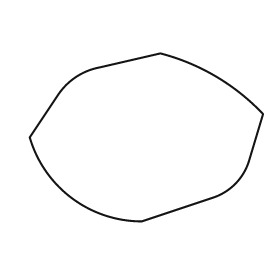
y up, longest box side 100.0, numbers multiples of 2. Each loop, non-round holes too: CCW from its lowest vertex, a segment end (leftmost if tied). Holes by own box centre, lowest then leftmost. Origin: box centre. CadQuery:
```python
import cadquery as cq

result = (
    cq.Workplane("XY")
    .moveTo(-2.0, -36.0)
    .lineTo(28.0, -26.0)
    .threePointArc((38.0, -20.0), (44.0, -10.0))
    .lineTo(50.0, 10.0)
    .threePointArc((30.0, 26.0), (6.0, 36.0))
    .lineTo(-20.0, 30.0)
    .threePointArc((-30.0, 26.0), (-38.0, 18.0))
    .lineTo(-50.0, 0.0)
    .threePointArc((-32.0, -26.0), (-2.0, -36.0))
    .close()
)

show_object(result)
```